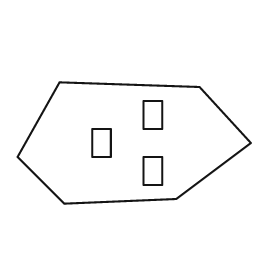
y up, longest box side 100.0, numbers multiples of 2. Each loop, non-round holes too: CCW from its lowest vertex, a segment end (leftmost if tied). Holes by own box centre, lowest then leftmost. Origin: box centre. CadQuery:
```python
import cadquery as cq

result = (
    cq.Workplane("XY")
    .moveTo(-30.0, -26.0)
    .lineTo(18.0, -24.0)
    .lineTo(50.0, 0.0)
    .lineTo(28.0, 24.0)
    .lineTo(-32.0, 26.0)
    .lineTo(-50.0, -6.0)
    .close()
    .moveTo(4.0, -18.0)
    .lineTo(12.0, -18.0)
    .lineTo(12.0, -6.0)
    .lineTo(4.0, -6.0)
    .close()
    .moveTo(-18.0, -6.0)
    .lineTo(-10.0, -6.0)
    .lineTo(-10.0, 6.0)
    .lineTo(-18.0, 6.0)
    .close()
    .moveTo(4.0, 6.0)
    .lineTo(12.0, 6.0)
    .lineTo(12.0, 18.0)
    .lineTo(4.0, 18.0)
    .close()
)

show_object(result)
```